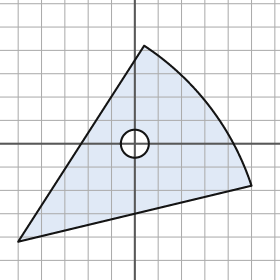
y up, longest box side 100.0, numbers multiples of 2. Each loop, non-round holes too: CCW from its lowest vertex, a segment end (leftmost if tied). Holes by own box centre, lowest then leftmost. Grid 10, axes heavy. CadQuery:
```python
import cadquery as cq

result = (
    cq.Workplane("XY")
    .moveTo(-50.0, -42.0)
    .lineTo(50.0, -18.0)
    .threePointArc((32.0, 16.0), (4.0, 42.0))
    .close()
    .moveTo(0.0, 0.0)
    .circle(6.0)
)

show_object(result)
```